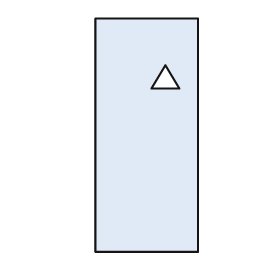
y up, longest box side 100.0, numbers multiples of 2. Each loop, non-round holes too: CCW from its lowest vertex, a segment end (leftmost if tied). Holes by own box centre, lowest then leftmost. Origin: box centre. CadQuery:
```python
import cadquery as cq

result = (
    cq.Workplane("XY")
    .moveTo(-22.0, -50.0)
    .lineTo(22.0, -50.0)
    .lineTo(22.0, 50.0)
    .lineTo(-22.0, 50.0)
    .close()
    .moveTo(2.0, 20.0)
    .lineTo(14.0, 20.0)
    .lineTo(8.0, 30.0)
    .close()
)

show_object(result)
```